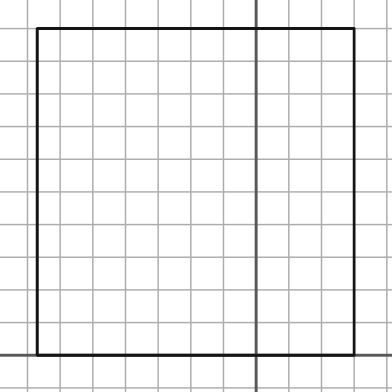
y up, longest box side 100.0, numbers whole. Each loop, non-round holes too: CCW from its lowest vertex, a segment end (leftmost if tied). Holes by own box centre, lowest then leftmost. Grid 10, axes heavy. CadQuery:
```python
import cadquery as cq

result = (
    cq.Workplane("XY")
    .moveTo(-67.0, 0.0)
    .lineTo(30.0, 0.0)
    .lineTo(30.0, 100.0)
    .lineTo(-67.0, 100.0)
    .close()
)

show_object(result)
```